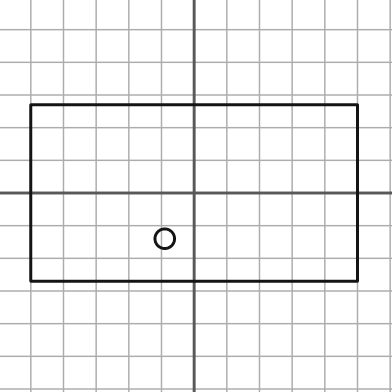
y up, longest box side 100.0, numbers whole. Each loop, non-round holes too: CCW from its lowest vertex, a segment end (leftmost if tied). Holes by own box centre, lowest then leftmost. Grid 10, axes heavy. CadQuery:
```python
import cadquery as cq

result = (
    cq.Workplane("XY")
    .moveTo(-50.0, -27.0)
    .lineTo(50.0, -27.0)
    .lineTo(50.0, 27.0)
    .lineTo(-50.0, 27.0)
    .close()
    .moveTo(-9.0, -14.0)
    .circle(3.0)
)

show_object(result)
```